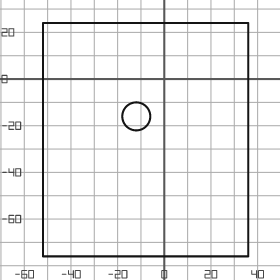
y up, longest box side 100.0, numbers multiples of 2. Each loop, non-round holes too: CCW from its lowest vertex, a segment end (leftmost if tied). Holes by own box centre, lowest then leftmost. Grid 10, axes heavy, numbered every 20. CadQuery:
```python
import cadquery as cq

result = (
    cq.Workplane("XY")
    .moveTo(-52.0, -76.0)
    .lineTo(36.0, -76.0)
    .lineTo(36.0, 24.0)
    .lineTo(-52.0, 24.0)
    .close()
    .moveTo(-12.0, -16.0)
    .circle(6.0)
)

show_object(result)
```